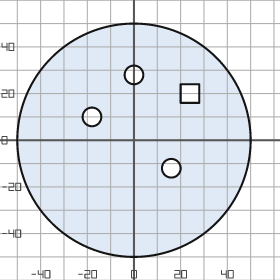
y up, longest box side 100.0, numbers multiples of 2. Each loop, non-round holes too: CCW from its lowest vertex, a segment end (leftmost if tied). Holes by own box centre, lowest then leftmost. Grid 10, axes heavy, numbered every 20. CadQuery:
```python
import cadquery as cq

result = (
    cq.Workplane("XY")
    .moveTo(0.0, 0.0)
    .circle(50.0)
    .moveTo(16.0, -12.0)
    .circle(4.0)
    .moveTo(-18.0, 10.0)
    .circle(4.0)
    .moveTo(20.0, 16.0)
    .lineTo(28.0, 16.0)
    .lineTo(28.0, 24.0)
    .lineTo(20.0, 24.0)
    .close()
    .moveTo(0.0, 28.0)
    .circle(4.0)
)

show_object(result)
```